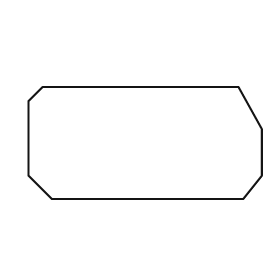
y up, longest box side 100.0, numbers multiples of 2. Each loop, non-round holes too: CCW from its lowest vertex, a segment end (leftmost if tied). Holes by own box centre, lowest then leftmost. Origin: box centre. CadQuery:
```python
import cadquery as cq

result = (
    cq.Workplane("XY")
    .moveTo(-40.0, -24.0)
    .lineTo(42.0, -24.0)
    .lineTo(50.0, -14.0)
    .lineTo(50.0, 6.0)
    .lineTo(40.0, 24.0)
    .lineTo(-44.0, 24.0)
    .lineTo(-50.0, 18.0)
    .lineTo(-50.0, -14.0)
    .close()
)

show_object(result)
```